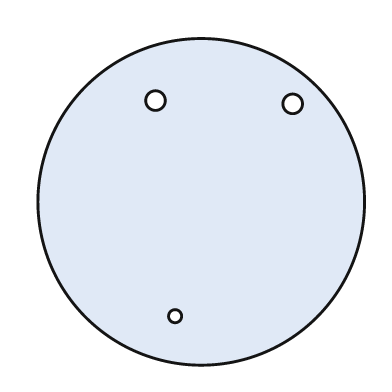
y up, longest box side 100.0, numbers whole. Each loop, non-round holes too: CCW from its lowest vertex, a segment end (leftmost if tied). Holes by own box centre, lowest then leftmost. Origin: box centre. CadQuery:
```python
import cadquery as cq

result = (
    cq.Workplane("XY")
    .moveTo(0.0, 0.0)
    .circle(50.0)
    .moveTo(-8.0, -35.0)
    .circle(2.0)
    .moveTo(28.0, 30.0)
    .circle(3.0)
    .moveTo(-14.0, 31.0)
    .circle(3.0)
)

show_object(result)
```